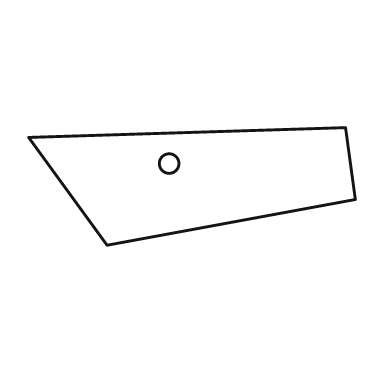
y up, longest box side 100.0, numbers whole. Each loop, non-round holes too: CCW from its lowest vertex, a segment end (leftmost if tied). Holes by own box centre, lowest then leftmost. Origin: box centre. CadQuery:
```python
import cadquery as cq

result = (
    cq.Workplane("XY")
    .moveTo(-26.0, -18.0)
    .lineTo(50.0, -4.0)
    .lineTo(47.0, 18.0)
    .lineTo(-50.0, 15.0)
    .close()
    .moveTo(-7.0, 7.0)
    .circle(3.0)
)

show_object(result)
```